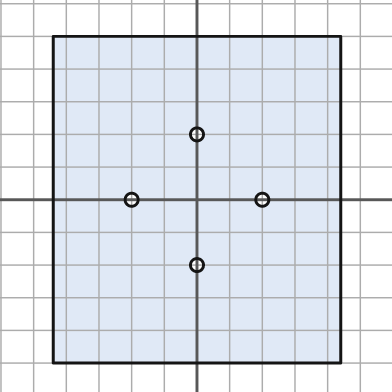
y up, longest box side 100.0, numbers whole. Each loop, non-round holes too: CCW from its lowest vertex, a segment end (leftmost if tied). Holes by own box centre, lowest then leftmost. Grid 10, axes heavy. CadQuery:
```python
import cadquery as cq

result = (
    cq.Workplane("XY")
    .moveTo(-44.0, -50.0)
    .lineTo(44.0, -50.0)
    .lineTo(44.0, 50.0)
    .lineTo(-44.0, 50.0)
    .close()
    .moveTo(0.0, -20.0)
    .circle(2.0)
    .moveTo(-20.0, 0.0)
    .circle(2.0)
    .moveTo(20.0, 0.0)
    .circle(2.0)
    .moveTo(0.0, 20.0)
    .circle(2.0)
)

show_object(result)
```